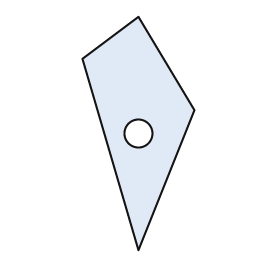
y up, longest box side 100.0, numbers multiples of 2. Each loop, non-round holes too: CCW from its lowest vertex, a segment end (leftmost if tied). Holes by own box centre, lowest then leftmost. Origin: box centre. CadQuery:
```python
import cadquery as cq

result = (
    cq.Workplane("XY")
    .moveTo(0.0, -50.0)
    .lineTo(24.0, 10.0)
    .lineTo(0.0, 50.0)
    .lineTo(-24.0, 32.0)
    .close()
    .moveTo(0.0, 0.0)
    .circle(6.0)
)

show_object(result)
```